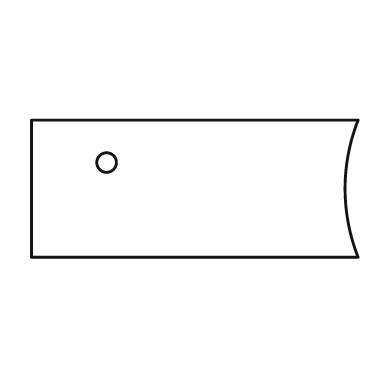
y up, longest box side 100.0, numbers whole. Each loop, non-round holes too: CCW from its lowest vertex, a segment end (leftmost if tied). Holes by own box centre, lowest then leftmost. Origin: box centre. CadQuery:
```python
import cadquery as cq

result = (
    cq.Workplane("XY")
    .moveTo(-50.0, -21.0)
    .lineTo(50.0, -21.0)
    .threePointArc((46.0, 0.0), (50.0, 21.0))
    .lineTo(-50.0, 21.0)
    .close()
    .moveTo(-27.0, 8.0)
    .circle(3.0)
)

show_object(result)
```